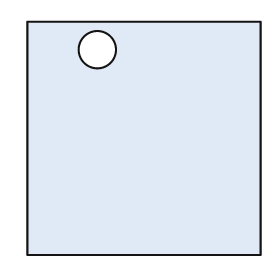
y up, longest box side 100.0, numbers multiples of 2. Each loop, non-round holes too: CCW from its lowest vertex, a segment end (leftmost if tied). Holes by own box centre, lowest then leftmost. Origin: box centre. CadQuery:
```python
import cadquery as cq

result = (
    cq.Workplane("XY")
    .moveTo(-50.0, -50.0)
    .lineTo(50.0, -50.0)
    .lineTo(50.0, 50.0)
    .lineTo(-50.0, 50.0)
    .close()
    .moveTo(-20.0, 38.0)
    .circle(8.0)
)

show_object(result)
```